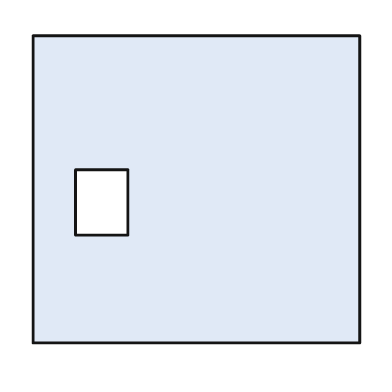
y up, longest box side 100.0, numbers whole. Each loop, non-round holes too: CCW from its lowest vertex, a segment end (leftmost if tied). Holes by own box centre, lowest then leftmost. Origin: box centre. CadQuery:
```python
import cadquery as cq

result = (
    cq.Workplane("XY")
    .moveTo(-50.0, -47.0)
    .lineTo(50.0, -47.0)
    .lineTo(50.0, 47.0)
    .lineTo(-50.0, 47.0)
    .close()
    .moveTo(-37.0, -14.0)
    .lineTo(-21.0, -14.0)
    .lineTo(-21.0, 6.0)
    .lineTo(-37.0, 6.0)
    .close()
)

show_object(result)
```